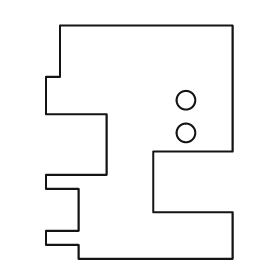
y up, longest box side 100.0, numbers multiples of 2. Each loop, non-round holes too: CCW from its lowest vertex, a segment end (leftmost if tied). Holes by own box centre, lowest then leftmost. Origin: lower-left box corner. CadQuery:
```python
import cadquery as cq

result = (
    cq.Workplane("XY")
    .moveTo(14.0, 0.0)
    .lineTo(80.0, 0.0)
    .lineTo(80.0, 20.0)
    .lineTo(46.0, 20.0)
    .lineTo(46.0, 46.0)
    .lineTo(80.0, 46.0)
    .lineTo(80.0, 100.0)
    .lineTo(6.0, 100.0)
    .lineTo(6.0, 78.0)
    .lineTo(0.0, 78.0)
    .lineTo(0.0, 62.0)
    .lineTo(26.0, 62.0)
    .lineTo(26.0, 36.0)
    .lineTo(0.0, 36.0)
    .lineTo(0.0, 30.0)
    .lineTo(14.0, 30.0)
    .lineTo(14.0, 12.0)
    .lineTo(0.0, 12.0)
    .lineTo(0.0, 6.0)
    .lineTo(14.0, 6.0)
    .close()
    .moveTo(60.0, 54.0)
    .circle(4.0)
    .moveTo(60.0, 68.0)
    .circle(4.0)
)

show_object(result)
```